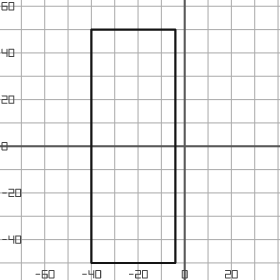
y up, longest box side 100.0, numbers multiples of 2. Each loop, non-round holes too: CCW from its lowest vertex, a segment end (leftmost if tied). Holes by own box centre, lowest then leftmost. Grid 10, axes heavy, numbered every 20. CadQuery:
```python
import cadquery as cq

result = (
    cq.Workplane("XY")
    .moveTo(-40.0, -50.0)
    .lineTo(-4.0, -50.0)
    .lineTo(-4.0, 50.0)
    .lineTo(-40.0, 50.0)
    .close()
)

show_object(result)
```